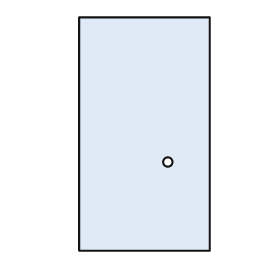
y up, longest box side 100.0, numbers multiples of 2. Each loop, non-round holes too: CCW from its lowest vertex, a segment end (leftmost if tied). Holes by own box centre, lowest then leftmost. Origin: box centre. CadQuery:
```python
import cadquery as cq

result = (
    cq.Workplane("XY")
    .moveTo(-28.0, -50.0)
    .lineTo(28.0, -50.0)
    .lineTo(28.0, 50.0)
    .lineTo(-28.0, 50.0)
    .close()
    .moveTo(10.0, -12.0)
    .circle(2.0)
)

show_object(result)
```